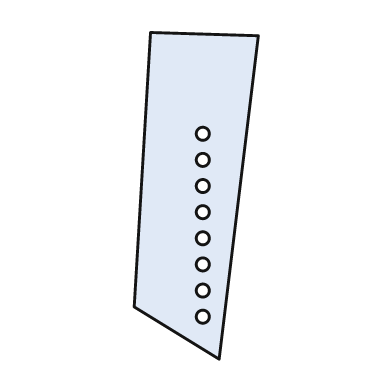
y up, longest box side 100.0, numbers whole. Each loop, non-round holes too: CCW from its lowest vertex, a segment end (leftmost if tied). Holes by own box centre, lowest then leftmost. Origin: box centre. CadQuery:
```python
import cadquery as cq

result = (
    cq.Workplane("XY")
    .moveTo(7.0, -50.0)
    .lineTo(19.0, 49.0)
    .lineTo(-14.0, 50.0)
    .lineTo(-19.0, -34.0)
    .close()
    .moveTo(2.0, -37.0)
    .circle(2.0)
    .moveTo(2.0, -29.0)
    .circle(2.0)
    .moveTo(2.0, -21.0)
    .circle(2.0)
    .moveTo(2.0, -13.0)
    .circle(2.0)
    .moveTo(2.0, -5.0)
    .circle(2.0)
    .moveTo(2.0, 3.0)
    .circle(2.0)
    .moveTo(2.0, 11.0)
    .circle(2.0)
    .moveTo(2.0, 19.0)
    .circle(2.0)
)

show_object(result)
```